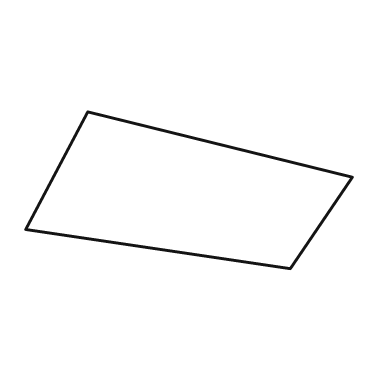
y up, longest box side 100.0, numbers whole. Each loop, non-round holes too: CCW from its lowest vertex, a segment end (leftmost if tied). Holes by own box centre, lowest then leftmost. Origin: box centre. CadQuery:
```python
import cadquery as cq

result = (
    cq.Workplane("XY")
    .moveTo(31.0, -24.0)
    .lineTo(50.0, 4.0)
    .lineTo(-31.0, 24.0)
    .lineTo(-50.0, -12.0)
    .close()
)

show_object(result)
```